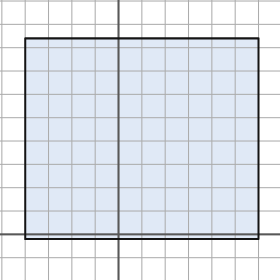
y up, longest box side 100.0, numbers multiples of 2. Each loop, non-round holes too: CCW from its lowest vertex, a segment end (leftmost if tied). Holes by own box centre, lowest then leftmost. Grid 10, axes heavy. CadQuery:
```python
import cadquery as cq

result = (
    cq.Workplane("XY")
    .moveTo(-40.0, -2.0)
    .lineTo(60.0, -2.0)
    .lineTo(60.0, 84.0)
    .lineTo(-40.0, 84.0)
    .close()
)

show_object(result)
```